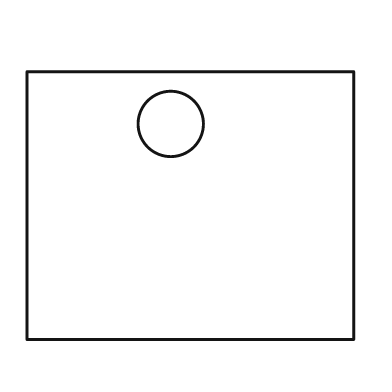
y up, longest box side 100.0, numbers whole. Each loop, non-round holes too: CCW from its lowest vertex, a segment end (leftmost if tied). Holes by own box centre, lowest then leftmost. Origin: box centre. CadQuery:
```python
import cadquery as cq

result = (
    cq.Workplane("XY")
    .moveTo(-50.0, -41.0)
    .lineTo(50.0, -41.0)
    .lineTo(50.0, 41.0)
    .lineTo(-50.0, 41.0)
    .close()
    .moveTo(-6.0, 25.0)
    .circle(10.0)
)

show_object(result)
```